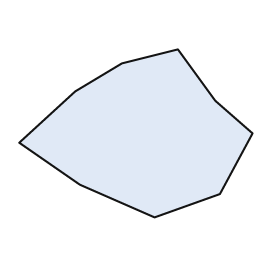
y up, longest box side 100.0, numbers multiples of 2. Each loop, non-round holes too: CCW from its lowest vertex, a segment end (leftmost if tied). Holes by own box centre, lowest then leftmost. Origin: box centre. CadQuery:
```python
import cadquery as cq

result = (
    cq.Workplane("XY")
    .moveTo(8.0, -36.0)
    .lineTo(36.0, -26.0)
    .lineTo(50.0, 0.0)
    .lineTo(34.0, 14.0)
    .lineTo(18.0, 36.0)
    .lineTo(-6.0, 30.0)
    .lineTo(-26.0, 18.0)
    .lineTo(-50.0, -4.0)
    .lineTo(-24.0, -22.0)
    .close()
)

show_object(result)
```